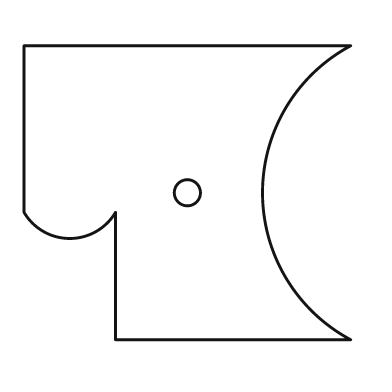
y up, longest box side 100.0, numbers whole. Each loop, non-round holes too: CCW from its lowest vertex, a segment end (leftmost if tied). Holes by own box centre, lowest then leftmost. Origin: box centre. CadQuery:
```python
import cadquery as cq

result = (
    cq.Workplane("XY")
    .moveTo(-22.0, -45.0)
    .lineTo(50.0, -45.0)
    .threePointArc((23.0, 0.0), (50.0, 45.0))
    .lineTo(-50.0, 45.0)
    .lineTo(-50.0, -6.0)
    .threePointArc((-36.0, -14.0), (-22.0, -6.0))
    .close()
    .moveTo(0.0, 0.0)
    .circle(4.0)
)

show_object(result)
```